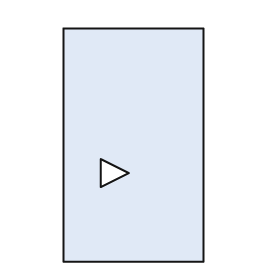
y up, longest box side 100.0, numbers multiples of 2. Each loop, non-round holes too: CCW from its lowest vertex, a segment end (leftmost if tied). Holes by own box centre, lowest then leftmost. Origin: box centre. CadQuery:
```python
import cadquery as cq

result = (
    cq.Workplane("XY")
    .moveTo(-30.0, -50.0)
    .lineTo(30.0, -50.0)
    .lineTo(30.0, 50.0)
    .lineTo(-30.0, 50.0)
    .close()
    .moveTo(-14.0, -18.0)
    .lineTo(-2.0, -12.0)
    .lineTo(-14.0, -6.0)
    .close()
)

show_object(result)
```